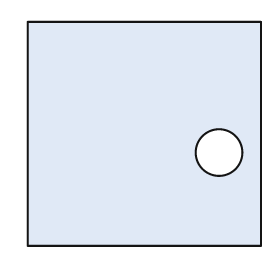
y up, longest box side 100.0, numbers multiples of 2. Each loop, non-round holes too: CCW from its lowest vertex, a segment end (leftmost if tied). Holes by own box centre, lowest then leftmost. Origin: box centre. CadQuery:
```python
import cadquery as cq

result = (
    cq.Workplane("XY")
    .moveTo(-50.0, -48.0)
    .lineTo(50.0, -48.0)
    .lineTo(50.0, 48.0)
    .lineTo(-50.0, 48.0)
    .close()
    .moveTo(32.0, -8.0)
    .circle(10.0)
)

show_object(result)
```